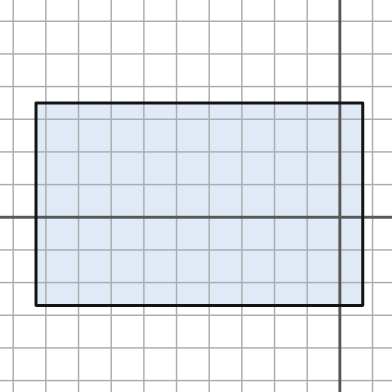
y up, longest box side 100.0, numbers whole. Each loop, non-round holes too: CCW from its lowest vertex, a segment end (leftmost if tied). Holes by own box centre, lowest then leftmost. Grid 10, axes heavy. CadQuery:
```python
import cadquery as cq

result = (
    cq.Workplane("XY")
    .moveTo(-93.0, -27.0)
    .lineTo(7.0, -27.0)
    .lineTo(7.0, 35.0)
    .lineTo(-93.0, 35.0)
    .close()
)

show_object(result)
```